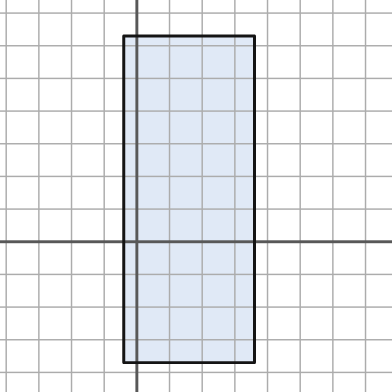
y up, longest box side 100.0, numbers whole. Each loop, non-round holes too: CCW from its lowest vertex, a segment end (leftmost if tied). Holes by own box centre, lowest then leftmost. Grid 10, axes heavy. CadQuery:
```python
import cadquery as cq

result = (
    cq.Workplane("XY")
    .moveTo(-4.0, -37.0)
    .lineTo(36.0, -37.0)
    .lineTo(36.0, 63.0)
    .lineTo(-4.0, 63.0)
    .close()
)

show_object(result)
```